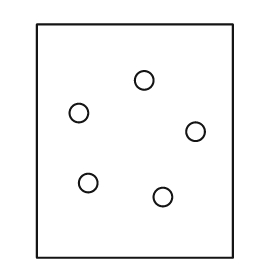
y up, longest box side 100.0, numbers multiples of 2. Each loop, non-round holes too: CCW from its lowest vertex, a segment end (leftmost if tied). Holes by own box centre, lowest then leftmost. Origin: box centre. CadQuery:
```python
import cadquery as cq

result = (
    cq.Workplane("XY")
    .moveTo(-42.0, -50.0)
    .lineTo(42.0, -50.0)
    .lineTo(42.0, 50.0)
    .lineTo(-42.0, 50.0)
    .close()
    .moveTo(12.0, -24.0)
    .circle(4.0)
    .moveTo(-20.0, -18.0)
    .circle(4.0)
    .moveTo(26.0, 4.0)
    .circle(4.0)
    .moveTo(-24.0, 12.0)
    .circle(4.0)
    .moveTo(4.0, 26.0)
    .circle(4.0)
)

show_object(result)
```